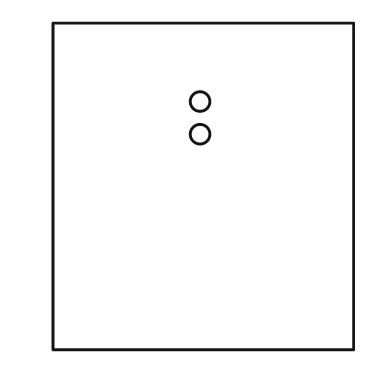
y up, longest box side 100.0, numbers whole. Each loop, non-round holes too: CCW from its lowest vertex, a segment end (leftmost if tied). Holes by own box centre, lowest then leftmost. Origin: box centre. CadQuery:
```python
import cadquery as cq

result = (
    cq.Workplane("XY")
    .moveTo(-46.0, -50.0)
    .lineTo(46.0, -50.0)
    .lineTo(46.0, 50.0)
    .lineTo(-46.0, 50.0)
    .close()
    .moveTo(-1.0, 16.0)
    .circle(3.0)
    .moveTo(-1.0, 26.0)
    .circle(3.0)
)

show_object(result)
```